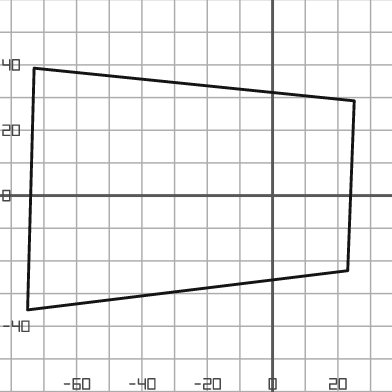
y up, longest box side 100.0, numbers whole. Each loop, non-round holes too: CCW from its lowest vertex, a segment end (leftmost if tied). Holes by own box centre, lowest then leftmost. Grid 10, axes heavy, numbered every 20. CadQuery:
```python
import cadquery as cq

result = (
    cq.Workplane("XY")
    .moveTo(-75.0, -35.0)
    .lineTo(23.0, -23.0)
    .lineTo(25.0, 29.0)
    .lineTo(-73.0, 39.0)
    .close()
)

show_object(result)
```